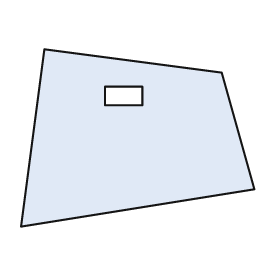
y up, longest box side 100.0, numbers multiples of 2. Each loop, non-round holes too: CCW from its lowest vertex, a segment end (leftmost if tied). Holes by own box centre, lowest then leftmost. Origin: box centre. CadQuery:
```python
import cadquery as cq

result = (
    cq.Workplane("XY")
    .moveTo(-50.0, -38.0)
    .lineTo(50.0, -22.0)
    .lineTo(36.0, 28.0)
    .lineTo(-40.0, 38.0)
    .close()
    .moveTo(-14.0, 14.0)
    .lineTo(2.0, 14.0)
    .lineTo(2.0, 22.0)
    .lineTo(-14.0, 22.0)
    .close()
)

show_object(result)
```